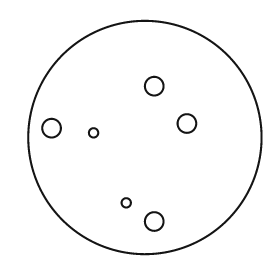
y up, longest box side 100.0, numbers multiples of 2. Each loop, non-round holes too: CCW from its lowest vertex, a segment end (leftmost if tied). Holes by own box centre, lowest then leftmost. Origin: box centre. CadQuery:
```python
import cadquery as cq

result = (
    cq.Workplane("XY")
    .moveTo(0.0, 0.0)
    .circle(50.0)
    .moveTo(4.0, -36.0)
    .circle(4.0)
    .moveTo(-8.0, -28.0)
    .circle(2.0)
    .moveTo(-22.0, 2.0)
    .circle(2.0)
    .moveTo(-40.0, 4.0)
    .circle(4.0)
    .moveTo(18.0, 6.0)
    .circle(4.0)
    .moveTo(4.0, 22.0)
    .circle(4.0)
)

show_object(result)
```